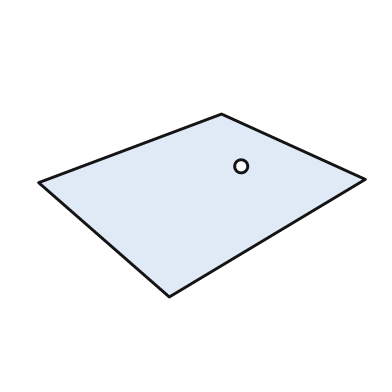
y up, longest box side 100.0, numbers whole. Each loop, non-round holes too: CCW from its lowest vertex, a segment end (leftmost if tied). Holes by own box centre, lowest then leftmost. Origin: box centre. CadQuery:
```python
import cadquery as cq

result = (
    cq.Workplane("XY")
    .moveTo(-10.0, -28.0)
    .lineTo(50.0, 8.0)
    .lineTo(6.0, 28.0)
    .lineTo(-50.0, 7.0)
    .close()
    .moveTo(12.0, 12.0)
    .circle(2.0)
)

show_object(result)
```